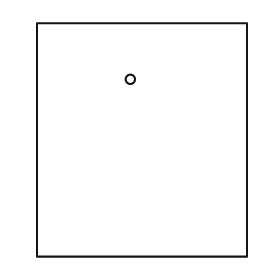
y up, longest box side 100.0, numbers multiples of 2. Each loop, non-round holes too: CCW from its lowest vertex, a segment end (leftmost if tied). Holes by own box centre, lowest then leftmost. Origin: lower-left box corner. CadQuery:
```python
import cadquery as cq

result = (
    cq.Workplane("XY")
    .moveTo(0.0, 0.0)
    .lineTo(90.0, 0.0)
    .lineTo(90.0, 100.0)
    .lineTo(0.0, 100.0)
    .close()
    .moveTo(40.0, 76.0)
    .circle(2.0)
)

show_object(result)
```